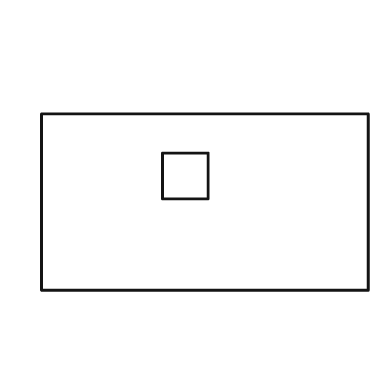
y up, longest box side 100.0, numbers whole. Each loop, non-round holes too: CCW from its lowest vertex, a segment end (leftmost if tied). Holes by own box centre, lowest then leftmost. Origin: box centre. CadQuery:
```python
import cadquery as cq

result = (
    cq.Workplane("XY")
    .moveTo(-50.0, -27.0)
    .lineTo(50.0, -27.0)
    .lineTo(50.0, 27.0)
    .lineTo(-50.0, 27.0)
    .close()
    .moveTo(-13.0, 1.0)
    .lineTo(1.0, 1.0)
    .lineTo(1.0, 15.0)
    .lineTo(-13.0, 15.0)
    .close()
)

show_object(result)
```